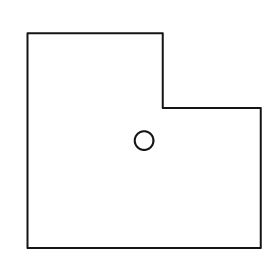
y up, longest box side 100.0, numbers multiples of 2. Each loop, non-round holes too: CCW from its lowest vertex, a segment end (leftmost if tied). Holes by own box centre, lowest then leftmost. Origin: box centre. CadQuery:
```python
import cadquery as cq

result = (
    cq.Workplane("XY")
    .moveTo(-50.0, -46.0)
    .lineTo(50.0, -46.0)
    .lineTo(50.0, 14.0)
    .lineTo(8.0, 14.0)
    .lineTo(8.0, 46.0)
    .lineTo(-50.0, 46.0)
    .close()
    .moveTo(0.0, 0.0)
    .circle(4.0)
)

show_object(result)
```